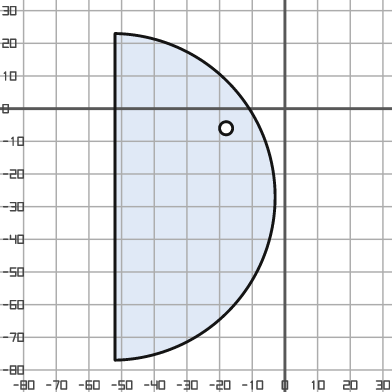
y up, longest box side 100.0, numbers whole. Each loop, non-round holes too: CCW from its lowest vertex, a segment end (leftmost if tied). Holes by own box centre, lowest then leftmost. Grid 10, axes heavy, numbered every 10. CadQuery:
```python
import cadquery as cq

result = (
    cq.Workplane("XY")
    .moveTo(-52.0, -77.0)
    .threePointArc((-3.0, -27.0), (-52.0, 23.0))
    .close()
    .moveTo(-18.0, -6.0)
    .circle(2.0)
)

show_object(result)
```